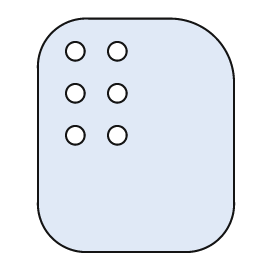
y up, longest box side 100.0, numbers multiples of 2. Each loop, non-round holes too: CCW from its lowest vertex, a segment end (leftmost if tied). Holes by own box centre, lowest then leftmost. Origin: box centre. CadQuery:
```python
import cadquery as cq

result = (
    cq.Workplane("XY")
    .moveTo(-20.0, -50.0)
    .lineTo(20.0, -50.0)
    .threePointArc((36.0, -44.0), (42.0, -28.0))
    .lineTo(42.0, 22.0)
    .threePointArc((34.0, 42.0), (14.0, 50.0))
    .lineTo(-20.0, 50.0)
    .threePointArc((-36.0, 44.0), (-42.0, 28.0))
    .lineTo(-42.0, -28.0)
    .threePointArc((-36.0, -44.0), (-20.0, -50.0))
    .close()
    .moveTo(-26.0, 0.0)
    .circle(4.0)
    .moveTo(-8.0, 0.0)
    .circle(4.0)
    .moveTo(-26.0, 18.0)
    .circle(4.0)
    .moveTo(-8.0, 18.0)
    .circle(4.0)
    .moveTo(-26.0, 36.0)
    .circle(4.0)
    .moveTo(-8.0, 36.0)
    .circle(4.0)
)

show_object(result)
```